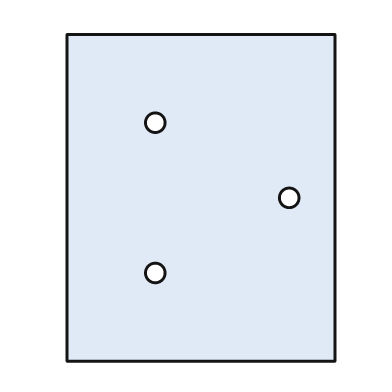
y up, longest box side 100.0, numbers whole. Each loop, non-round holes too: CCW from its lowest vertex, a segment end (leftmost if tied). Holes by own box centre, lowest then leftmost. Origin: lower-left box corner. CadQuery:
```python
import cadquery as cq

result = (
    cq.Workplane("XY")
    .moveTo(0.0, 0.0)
    .lineTo(82.0, 0.0)
    .lineTo(82.0, 100.0)
    .lineTo(0.0, 100.0)
    .close()
    .moveTo(27.0, 27.0)
    .circle(3.0)
    .moveTo(68.0, 50.0)
    .circle(3.0)
    .moveTo(27.0, 73.0)
    .circle(3.0)
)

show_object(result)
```